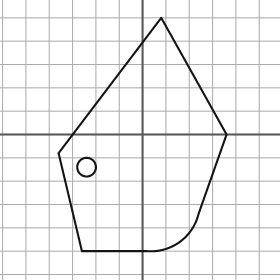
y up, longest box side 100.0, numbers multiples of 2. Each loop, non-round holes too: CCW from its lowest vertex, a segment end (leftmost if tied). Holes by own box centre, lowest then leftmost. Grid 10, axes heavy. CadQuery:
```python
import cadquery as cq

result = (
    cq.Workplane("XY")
    .moveTo(-26.0, -50.0)
    .lineTo(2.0, -50.0)
    .threePointArc((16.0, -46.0), (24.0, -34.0))
    .lineTo(36.0, 0.0)
    .lineTo(8.0, 50.0)
    .lineTo(-36.0, -8.0)
    .close()
    .moveTo(-24.0, -14.0)
    .circle(4.0)
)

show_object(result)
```